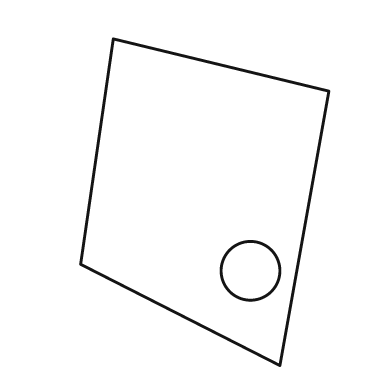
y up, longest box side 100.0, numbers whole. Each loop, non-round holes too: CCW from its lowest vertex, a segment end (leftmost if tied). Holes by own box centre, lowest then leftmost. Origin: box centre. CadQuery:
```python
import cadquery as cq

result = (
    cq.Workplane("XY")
    .moveTo(23.0, -50.0)
    .lineTo(38.0, 34.0)
    .lineTo(-28.0, 50.0)
    .lineTo(-38.0, -19.0)
    .close()
    .moveTo(14.0, -21.0)
    .circle(9.0)
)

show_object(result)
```